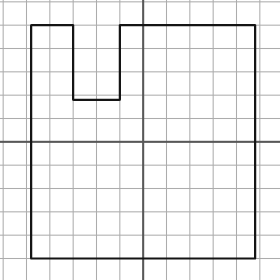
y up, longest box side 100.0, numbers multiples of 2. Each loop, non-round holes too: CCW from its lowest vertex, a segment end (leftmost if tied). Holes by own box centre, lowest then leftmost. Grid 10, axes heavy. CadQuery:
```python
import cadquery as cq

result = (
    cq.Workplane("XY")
    .moveTo(-48.0, -50.0)
    .lineTo(48.0, -50.0)
    .lineTo(48.0, 50.0)
    .lineTo(-10.0, 50.0)
    .lineTo(-10.0, 18.0)
    .lineTo(-30.0, 18.0)
    .lineTo(-30.0, 50.0)
    .lineTo(-48.0, 50.0)
    .close()
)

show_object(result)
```